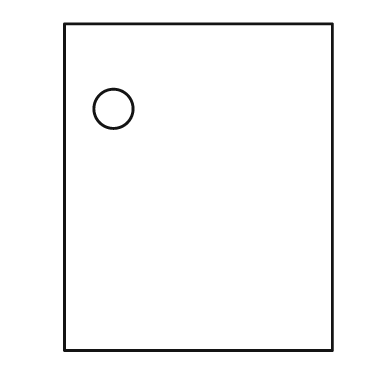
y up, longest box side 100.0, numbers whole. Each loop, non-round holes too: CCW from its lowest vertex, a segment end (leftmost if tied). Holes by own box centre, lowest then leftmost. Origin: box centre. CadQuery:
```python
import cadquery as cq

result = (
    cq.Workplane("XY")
    .moveTo(-41.0, -50.0)
    .lineTo(41.0, -50.0)
    .lineTo(41.0, 50.0)
    .lineTo(-41.0, 50.0)
    .close()
    .moveTo(-26.0, 24.0)
    .circle(6.0)
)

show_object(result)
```